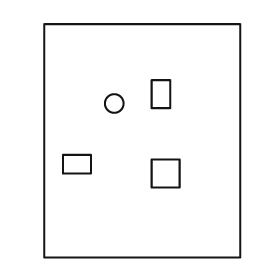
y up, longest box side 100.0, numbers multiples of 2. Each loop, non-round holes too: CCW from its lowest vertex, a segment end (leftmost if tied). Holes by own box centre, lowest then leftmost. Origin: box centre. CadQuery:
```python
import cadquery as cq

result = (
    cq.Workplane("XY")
    .moveTo(-42.0, -50.0)
    .lineTo(42.0, -50.0)
    .lineTo(42.0, 50.0)
    .lineTo(-42.0, 50.0)
    .close()
    .moveTo(4.0, -20.0)
    .lineTo(16.0, -20.0)
    .lineTo(16.0, -8.0)
    .lineTo(4.0, -8.0)
    .close()
    .moveTo(-34.0, -14.0)
    .lineTo(-22.0, -14.0)
    .lineTo(-22.0, -6.0)
    .lineTo(-34.0, -6.0)
    .close()
    .moveTo(-12.0, 16.0)
    .circle(4.0)
    .moveTo(4.0, 14.0)
    .lineTo(12.0, 14.0)
    .lineTo(12.0, 26.0)
    .lineTo(4.0, 26.0)
    .close()
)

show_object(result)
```